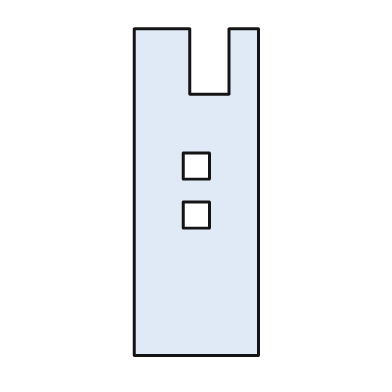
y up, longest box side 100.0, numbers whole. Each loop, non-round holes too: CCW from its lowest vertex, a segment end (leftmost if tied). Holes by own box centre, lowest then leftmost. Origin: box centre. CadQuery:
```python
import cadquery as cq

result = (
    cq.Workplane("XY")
    .moveTo(-19.0, -50.0)
    .lineTo(19.0, -50.0)
    .lineTo(19.0, 50.0)
    .lineTo(10.0, 50.0)
    .lineTo(10.0, 30.0)
    .lineTo(-2.0, 30.0)
    .lineTo(-2.0, 50.0)
    .lineTo(-19.0, 50.0)
    .close()
    .moveTo(-4.0, -11.0)
    .lineTo(4.0, -11.0)
    .lineTo(4.0, -3.0)
    .lineTo(-4.0, -3.0)
    .close()
    .moveTo(-4.0, 4.0)
    .lineTo(4.0, 4.0)
    .lineTo(4.0, 12.0)
    .lineTo(-4.0, 12.0)
    .close()
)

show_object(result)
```